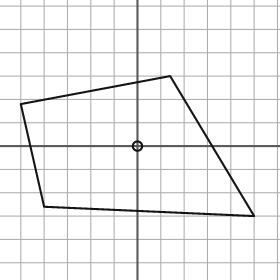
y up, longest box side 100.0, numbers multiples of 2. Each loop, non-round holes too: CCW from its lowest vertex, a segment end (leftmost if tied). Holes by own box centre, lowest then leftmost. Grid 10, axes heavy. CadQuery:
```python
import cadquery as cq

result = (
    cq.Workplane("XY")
    .moveTo(50.0, -30.0)
    .lineTo(14.0, 30.0)
    .lineTo(-50.0, 18.0)
    .lineTo(-40.0, -26.0)
    .close()
    .moveTo(0.0, 0.0)
    .circle(2.0)
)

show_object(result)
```